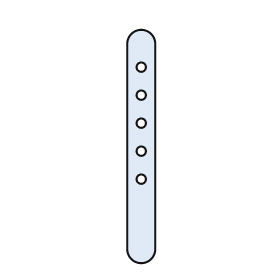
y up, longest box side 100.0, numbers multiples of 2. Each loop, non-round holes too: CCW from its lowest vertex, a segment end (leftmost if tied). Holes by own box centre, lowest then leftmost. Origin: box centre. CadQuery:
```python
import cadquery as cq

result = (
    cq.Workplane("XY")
    .moveTo(-6.0, -44.0)
    .threePointArc((0.0, -50.0), (6.0, -44.0))
    .lineTo(6.0, 44.0)
    .threePointArc((0.0, 50.0), (-6.0, 44.0))
    .close()
    .moveTo(0.0, -14.0)
    .circle(2.0)
    .moveTo(0.0, -2.0)
    .circle(2.0)
    .moveTo(0.0, 10.0)
    .circle(2.0)
    .moveTo(0.0, 22.0)
    .circle(2.0)
    .moveTo(0.0, 34.0)
    .circle(2.0)
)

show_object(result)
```